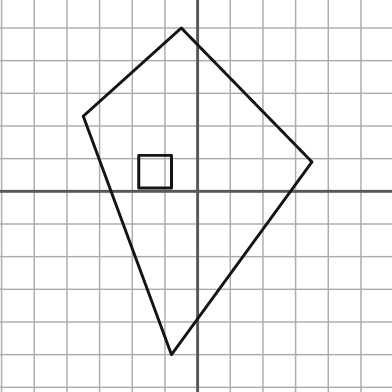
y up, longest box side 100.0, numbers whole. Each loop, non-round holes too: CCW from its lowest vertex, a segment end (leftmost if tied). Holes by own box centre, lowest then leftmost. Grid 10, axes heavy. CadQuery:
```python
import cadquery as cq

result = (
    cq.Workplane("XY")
    .moveTo(-8.0, -50.0)
    .lineTo(35.0, 9.0)
    .lineTo(-5.0, 50.0)
    .lineTo(-35.0, 23.0)
    .close()
    .moveTo(-18.0, 1.0)
    .lineTo(-8.0, 1.0)
    .lineTo(-8.0, 11.0)
    .lineTo(-18.0, 11.0)
    .close()
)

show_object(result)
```